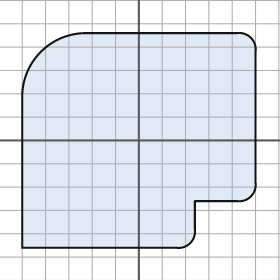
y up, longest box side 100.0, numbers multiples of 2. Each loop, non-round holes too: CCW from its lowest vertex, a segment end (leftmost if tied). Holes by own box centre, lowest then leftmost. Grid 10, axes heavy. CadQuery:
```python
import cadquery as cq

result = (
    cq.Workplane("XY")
    .moveTo(-50.0, -46.0)
    .lineTo(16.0, -46.0)
    .threePointArc((22.0, -44.0), (24.0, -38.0))
    .lineTo(24.0, -26.0)
    .lineTo(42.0, -26.0)
    .threePointArc((48.0, -24.0), (50.0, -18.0))
    .lineTo(50.0, 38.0)
    .threePointArc((48.0, 44.0), (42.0, 46.0))
    .lineTo(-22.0, 46.0)
    .threePointArc((-42.0, 38.0), (-50.0, 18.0))
    .close()
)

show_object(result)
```